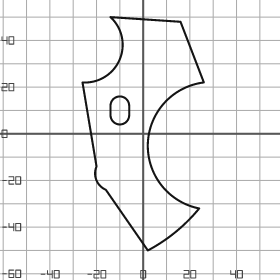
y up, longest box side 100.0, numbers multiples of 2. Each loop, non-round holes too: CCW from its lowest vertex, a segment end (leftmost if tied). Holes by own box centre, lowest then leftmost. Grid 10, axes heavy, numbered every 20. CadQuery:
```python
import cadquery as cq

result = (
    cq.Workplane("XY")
    .moveTo(2.0, -50.0)
    .threePointArc((14.0, -42.0), (24.0, -32.0))
    .threePointArc((2.0, -4.0), (26.0, 22.0))
    .lineTo(16.0, 48.0)
    .lineTo(-14.0, 50.0)
    .threePointArc((-10.0, 32.0), (-26.0, 22.0))
    .lineTo(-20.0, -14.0)
    .threePointArc((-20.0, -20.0), (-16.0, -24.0))
    .close()
    .moveTo(-14.0, 8.0)
    .threePointArc((-10.0, 4.0), (-6.0, 8.0))
    .lineTo(-6.0, 12.0)
    .threePointArc((-10.0, 16.0), (-14.0, 12.0))
    .close()
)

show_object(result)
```